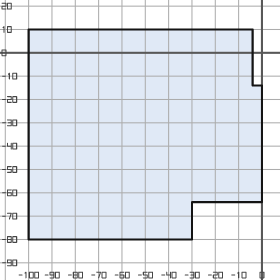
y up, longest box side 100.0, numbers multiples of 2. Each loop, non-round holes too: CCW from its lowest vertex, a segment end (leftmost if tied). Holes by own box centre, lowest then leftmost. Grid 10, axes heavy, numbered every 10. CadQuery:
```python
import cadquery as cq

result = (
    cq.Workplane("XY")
    .moveTo(-100.0, -80.0)
    .lineTo(-30.0, -80.0)
    .lineTo(-30.0, -64.0)
    .lineTo(0.0, -64.0)
    .lineTo(0.0, -14.0)
    .lineTo(-4.0, -14.0)
    .lineTo(-4.0, 10.0)
    .lineTo(-100.0, 10.0)
    .close()
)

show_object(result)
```